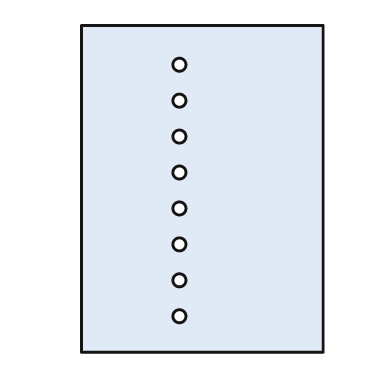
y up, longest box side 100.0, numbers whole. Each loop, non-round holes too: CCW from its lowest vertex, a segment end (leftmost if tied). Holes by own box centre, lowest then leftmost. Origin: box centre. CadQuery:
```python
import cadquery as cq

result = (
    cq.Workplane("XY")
    .moveTo(-37.0, -50.0)
    .lineTo(37.0, -50.0)
    .lineTo(37.0, 50.0)
    .lineTo(-37.0, 50.0)
    .close()
    .moveTo(-7.0, -39.0)
    .circle(2.0)
    .moveTo(-7.0, -28.0)
    .circle(2.0)
    .moveTo(-7.0, -17.0)
    .circle(2.0)
    .moveTo(-7.0, -6.0)
    .circle(2.0)
    .moveTo(-7.0, 5.0)
    .circle(2.0)
    .moveTo(-7.0, 16.0)
    .circle(2.0)
    .moveTo(-7.0, 27.0)
    .circle(2.0)
    .moveTo(-7.0, 38.0)
    .circle(2.0)
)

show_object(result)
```